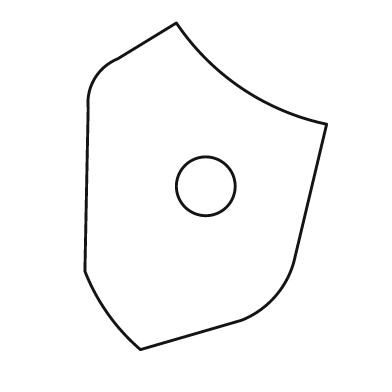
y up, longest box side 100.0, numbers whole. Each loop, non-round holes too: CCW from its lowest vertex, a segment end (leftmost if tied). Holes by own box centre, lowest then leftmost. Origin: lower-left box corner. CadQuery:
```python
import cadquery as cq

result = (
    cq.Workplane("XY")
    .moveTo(17.0, 0.0)
    .lineTo(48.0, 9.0)
    .threePointArc((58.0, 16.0), (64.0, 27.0))
    .lineTo(74.0, 69.0)
    .threePointArc((48.0, 80.0), (28.0, 100.0))
    .lineTo(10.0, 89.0)
    .threePointArc((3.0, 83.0), (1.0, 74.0))
    .lineTo(0.0, 24.0)
    .threePointArc((7.0, 11.0), (17.0, 0.0))
    .close()
    .moveTo(37.0, 50.0)
    .circle(9.0)
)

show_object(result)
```